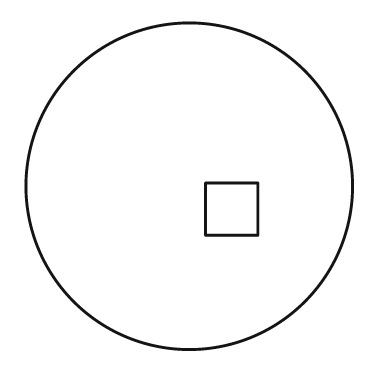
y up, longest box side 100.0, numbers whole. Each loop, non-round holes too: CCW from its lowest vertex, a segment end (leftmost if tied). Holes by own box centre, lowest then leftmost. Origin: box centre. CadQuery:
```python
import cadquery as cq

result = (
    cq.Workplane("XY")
    .moveTo(0.0, 0.0)
    .circle(50.0)
    .moveTo(5.0, -15.0)
    .lineTo(21.0, -15.0)
    .lineTo(21.0, 1.0)
    .lineTo(5.0, 1.0)
    .close()
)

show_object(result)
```